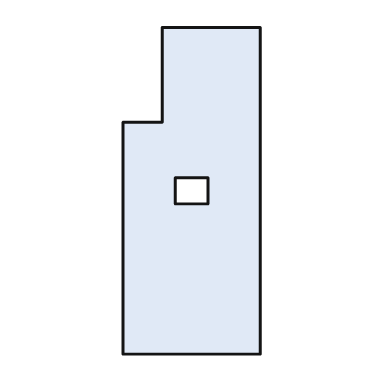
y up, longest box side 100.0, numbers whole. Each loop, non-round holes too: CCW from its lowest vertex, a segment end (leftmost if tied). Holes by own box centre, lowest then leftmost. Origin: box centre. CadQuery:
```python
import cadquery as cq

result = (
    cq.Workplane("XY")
    .moveTo(-21.0, -50.0)
    .lineTo(21.0, -50.0)
    .lineTo(21.0, 50.0)
    .lineTo(-9.0, 50.0)
    .lineTo(-9.0, 21.0)
    .lineTo(-21.0, 21.0)
    .close()
    .moveTo(-5.0, -4.0)
    .lineTo(5.0, -4.0)
    .lineTo(5.0, 4.0)
    .lineTo(-5.0, 4.0)
    .close()
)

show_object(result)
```